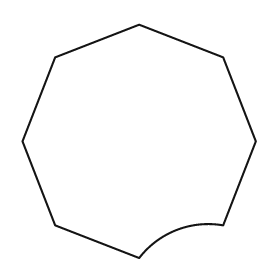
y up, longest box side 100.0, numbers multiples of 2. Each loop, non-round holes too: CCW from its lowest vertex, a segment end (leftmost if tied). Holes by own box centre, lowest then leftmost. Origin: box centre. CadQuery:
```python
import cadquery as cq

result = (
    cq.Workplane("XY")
    .moveTo(0.0, -50.0)
    .threePointArc((16.0, -38.0), (36.0, -36.0))
    .lineTo(50.0, 0.0)
    .lineTo(36.0, 36.0)
    .lineTo(0.0, 50.0)
    .lineTo(-36.0, 36.0)
    .lineTo(-50.0, 0.0)
    .lineTo(-36.0, -36.0)
    .close()
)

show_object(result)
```